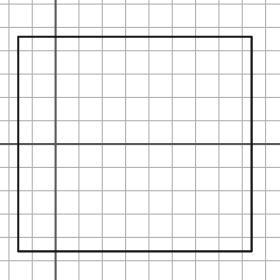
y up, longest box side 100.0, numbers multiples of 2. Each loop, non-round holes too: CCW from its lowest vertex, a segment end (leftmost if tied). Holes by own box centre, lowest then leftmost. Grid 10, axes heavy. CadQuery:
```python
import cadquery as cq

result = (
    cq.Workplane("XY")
    .moveTo(-16.0, -46.0)
    .lineTo(84.0, -46.0)
    .lineTo(84.0, 46.0)
    .lineTo(-16.0, 46.0)
    .close()
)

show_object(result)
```